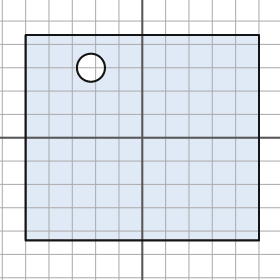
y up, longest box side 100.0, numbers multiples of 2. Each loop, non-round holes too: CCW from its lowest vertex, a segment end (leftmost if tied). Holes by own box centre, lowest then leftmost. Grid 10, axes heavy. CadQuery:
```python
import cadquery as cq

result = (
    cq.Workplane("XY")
    .moveTo(-50.0, -44.0)
    .lineTo(50.0, -44.0)
    .lineTo(50.0, 44.0)
    .lineTo(-50.0, 44.0)
    .close()
    .moveTo(-22.0, 30.0)
    .circle(6.0)
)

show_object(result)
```